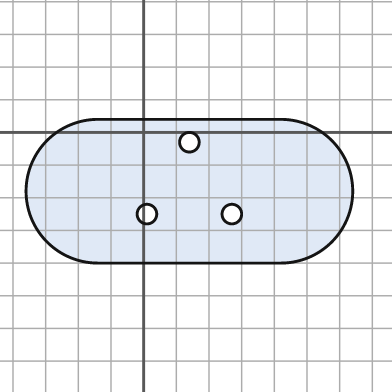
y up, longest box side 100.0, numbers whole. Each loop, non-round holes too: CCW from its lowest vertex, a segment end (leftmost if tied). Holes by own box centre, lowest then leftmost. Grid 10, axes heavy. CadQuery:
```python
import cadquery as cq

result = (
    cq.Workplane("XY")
    .moveTo(-14.0, -40.0)
    .lineTo(42.0, -40.0)
    .threePointArc((64.0, -18.0), (42.0, 4.0))
    .lineTo(-14.0, 4.0)
    .threePointArc((-36.0, -18.0), (-14.0, -40.0))
    .close()
    .moveTo(1.0, -25.0)
    .circle(3.0)
    .moveTo(27.0, -25.0)
    .circle(3.0)
    .moveTo(14.0, -3.0)
    .circle(3.0)
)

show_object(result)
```